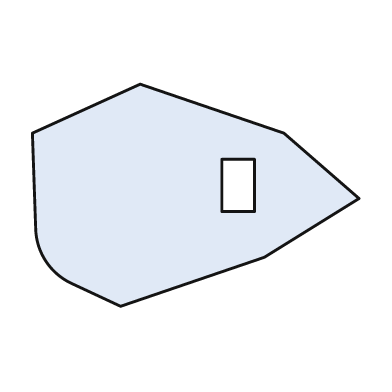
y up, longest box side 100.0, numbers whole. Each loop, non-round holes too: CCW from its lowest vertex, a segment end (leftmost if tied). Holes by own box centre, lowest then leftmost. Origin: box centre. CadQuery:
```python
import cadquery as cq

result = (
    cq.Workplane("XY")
    .moveTo(-23.0, -34.0)
    .lineTo(21.0, -19.0)
    .lineTo(50.0, -1.0)
    .lineTo(27.0, 19.0)
    .lineTo(-17.0, 34.0)
    .lineTo(-50.0, 19.0)
    .lineTo(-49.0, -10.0)
    .threePointArc((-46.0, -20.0), (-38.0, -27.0))
    .close()
    .moveTo(8.0, -5.0)
    .lineTo(18.0, -5.0)
    .lineTo(18.0, 11.0)
    .lineTo(8.0, 11.0)
    .close()
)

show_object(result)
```